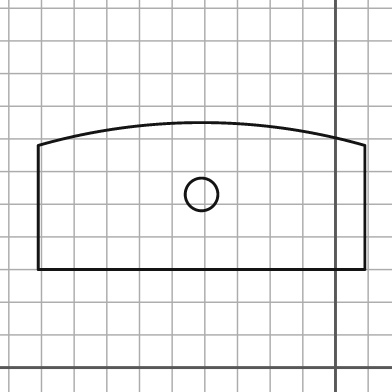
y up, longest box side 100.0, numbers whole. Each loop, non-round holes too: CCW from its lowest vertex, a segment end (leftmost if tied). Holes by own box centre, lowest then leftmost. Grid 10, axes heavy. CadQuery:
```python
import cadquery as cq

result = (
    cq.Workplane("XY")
    .moveTo(-91.0, 30.0)
    .lineTo(9.0, 30.0)
    .lineTo(9.0, 68.0)
    .threePointArc((-41.0, 75.0), (-91.0, 68.0))
    .close()
    .moveTo(-41.0, 53.0)
    .circle(5.0)
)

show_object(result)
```